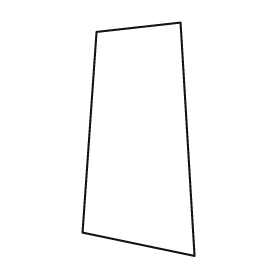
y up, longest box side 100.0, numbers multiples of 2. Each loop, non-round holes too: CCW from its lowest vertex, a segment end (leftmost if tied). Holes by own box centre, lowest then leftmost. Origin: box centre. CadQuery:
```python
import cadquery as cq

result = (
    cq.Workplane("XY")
    .moveTo(24.0, -50.0)
    .lineTo(18.0, 50.0)
    .lineTo(-18.0, 46.0)
    .lineTo(-24.0, -40.0)
    .close()
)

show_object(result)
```